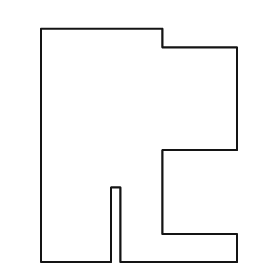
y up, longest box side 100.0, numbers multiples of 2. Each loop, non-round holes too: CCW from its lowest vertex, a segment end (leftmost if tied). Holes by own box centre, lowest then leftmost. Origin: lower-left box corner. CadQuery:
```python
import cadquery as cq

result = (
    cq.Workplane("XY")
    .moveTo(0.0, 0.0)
    .lineTo(30.0, 0.0)
    .lineTo(30.0, 32.0)
    .lineTo(34.0, 32.0)
    .lineTo(34.0, 0.0)
    .lineTo(84.0, 0.0)
    .lineTo(84.0, 12.0)
    .lineTo(52.0, 12.0)
    .lineTo(52.0, 48.0)
    .lineTo(84.0, 48.0)
    .lineTo(84.0, 92.0)
    .lineTo(52.0, 92.0)
    .lineTo(52.0, 100.0)
    .lineTo(0.0, 100.0)
    .close()
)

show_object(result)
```